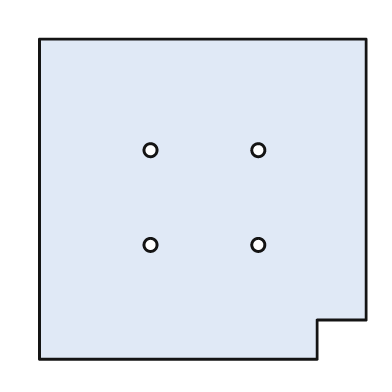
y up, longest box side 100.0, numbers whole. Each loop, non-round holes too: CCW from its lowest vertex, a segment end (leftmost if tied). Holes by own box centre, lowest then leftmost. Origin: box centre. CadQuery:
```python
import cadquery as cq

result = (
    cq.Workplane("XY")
    .moveTo(-50.0, -49.0)
    .lineTo(35.0, -49.0)
    .lineTo(35.0, -37.0)
    .lineTo(50.0, -37.0)
    .lineTo(50.0, 49.0)
    .lineTo(-50.0, 49.0)
    .close()
    .moveTo(-16.0, -14.0)
    .circle(2.0)
    .moveTo(17.0, -14.0)
    .circle(2.0)
    .moveTo(-16.0, 15.0)
    .circle(2.0)
    .moveTo(17.0, 15.0)
    .circle(2.0)
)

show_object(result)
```